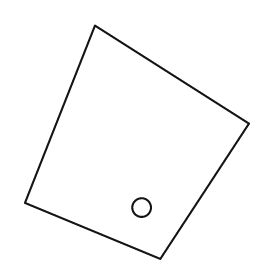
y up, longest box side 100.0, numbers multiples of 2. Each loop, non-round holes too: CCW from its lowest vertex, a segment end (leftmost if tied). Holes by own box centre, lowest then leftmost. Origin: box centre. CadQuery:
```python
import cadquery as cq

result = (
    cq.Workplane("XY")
    .moveTo(10.0, -50.0)
    .lineTo(48.0, 8.0)
    .lineTo(-18.0, 50.0)
    .lineTo(-48.0, -26.0)
    .close()
    .moveTo(2.0, -28.0)
    .circle(4.0)
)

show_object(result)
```